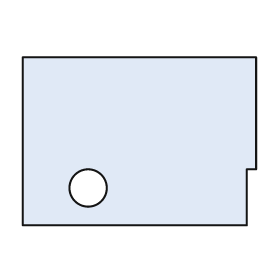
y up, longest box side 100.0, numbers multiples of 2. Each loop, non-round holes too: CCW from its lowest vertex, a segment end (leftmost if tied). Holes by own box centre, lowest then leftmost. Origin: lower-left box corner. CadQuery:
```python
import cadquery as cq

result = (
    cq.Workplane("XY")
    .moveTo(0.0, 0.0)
    .lineTo(96.0, 0.0)
    .lineTo(96.0, 24.0)
    .lineTo(100.0, 24.0)
    .lineTo(100.0, 72.0)
    .lineTo(0.0, 72.0)
    .close()
    .moveTo(28.0, 16.0)
    .circle(8.0)
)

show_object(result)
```